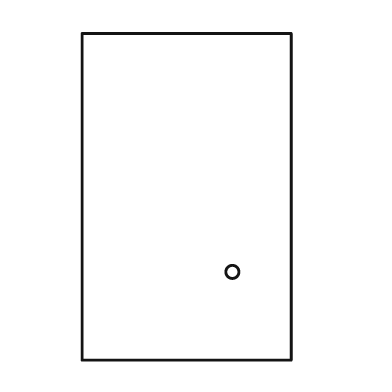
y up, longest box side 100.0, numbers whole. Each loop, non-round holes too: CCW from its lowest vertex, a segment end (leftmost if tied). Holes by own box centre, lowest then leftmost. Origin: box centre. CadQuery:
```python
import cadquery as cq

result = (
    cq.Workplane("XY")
    .moveTo(-32.0, -50.0)
    .lineTo(32.0, -50.0)
    .lineTo(32.0, 50.0)
    .lineTo(-32.0, 50.0)
    .close()
    .moveTo(14.0, -23.0)
    .circle(2.0)
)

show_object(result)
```